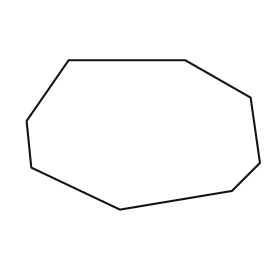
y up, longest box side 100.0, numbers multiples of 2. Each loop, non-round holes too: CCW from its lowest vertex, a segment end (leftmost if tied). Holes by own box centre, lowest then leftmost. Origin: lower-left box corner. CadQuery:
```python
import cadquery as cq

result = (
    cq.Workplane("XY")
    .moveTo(40.0, 0.0)
    .lineTo(88.0, 8.0)
    .lineTo(100.0, 20.0)
    .lineTo(96.0, 48.0)
    .lineTo(68.0, 64.0)
    .lineTo(18.0, 64.0)
    .lineTo(0.0, 38.0)
    .lineTo(2.0, 18.0)
    .close()
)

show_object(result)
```